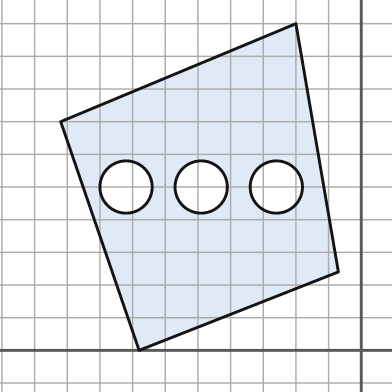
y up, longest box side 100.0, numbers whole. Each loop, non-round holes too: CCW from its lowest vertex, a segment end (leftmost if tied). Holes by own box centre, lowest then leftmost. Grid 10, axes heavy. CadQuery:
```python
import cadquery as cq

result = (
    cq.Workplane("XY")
    .moveTo(-68.0, 0.0)
    .lineTo(-7.0, 24.0)
    .lineTo(-20.0, 100.0)
    .lineTo(-92.0, 70.0)
    .close()
    .moveTo(-72.0, 50.0)
    .circle(8.0)
    .moveTo(-49.0, 50.0)
    .circle(8.0)
    .moveTo(-26.0, 50.0)
    .circle(8.0)
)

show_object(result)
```